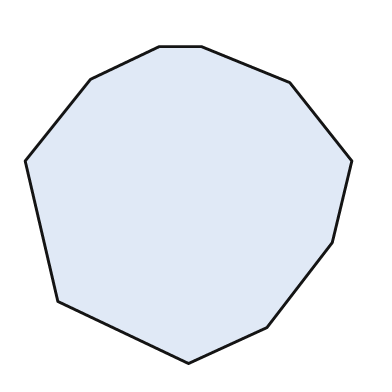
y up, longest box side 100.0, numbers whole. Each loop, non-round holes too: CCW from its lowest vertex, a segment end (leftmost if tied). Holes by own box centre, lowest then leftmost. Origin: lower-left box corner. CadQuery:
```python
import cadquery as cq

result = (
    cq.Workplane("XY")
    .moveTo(50.0, 0.0)
    .lineTo(74.0, 11.0)
    .lineTo(94.0, 37.0)
    .lineTo(100.0, 62.0)
    .lineTo(81.0, 86.0)
    .lineTo(54.0, 97.0)
    .lineTo(41.0, 97.0)
    .lineTo(20.0, 87.0)
    .lineTo(0.0, 62.0)
    .lineTo(10.0, 19.0)
    .close()
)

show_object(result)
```